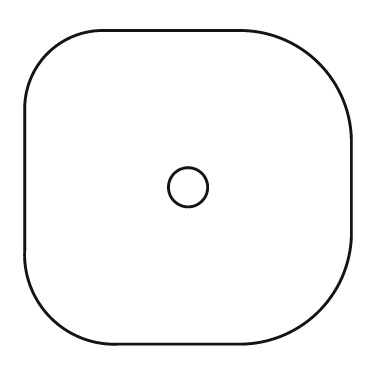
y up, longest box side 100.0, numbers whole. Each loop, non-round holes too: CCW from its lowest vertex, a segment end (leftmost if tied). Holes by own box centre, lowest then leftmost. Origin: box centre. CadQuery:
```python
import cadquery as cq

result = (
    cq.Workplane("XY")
    .moveTo(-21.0, -48.0)
    .lineTo(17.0, -48.0)
    .threePointArc((40.0, -38.0), (50.0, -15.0))
    .lineTo(50.0, 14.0)
    .threePointArc((40.0, 38.0), (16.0, 48.0))
    .lineTo(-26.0, 48.0)
    .threePointArc((-43.0, 41.0), (-50.0, 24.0))
    .lineTo(-50.0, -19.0)
    .threePointArc((-42.0, -40.0), (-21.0, -48.0))
    .close()
    .moveTo(0.0, 0.0)
    .circle(6.0)
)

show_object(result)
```